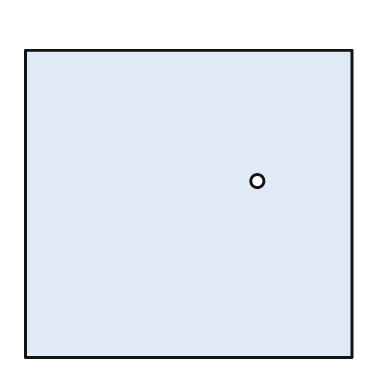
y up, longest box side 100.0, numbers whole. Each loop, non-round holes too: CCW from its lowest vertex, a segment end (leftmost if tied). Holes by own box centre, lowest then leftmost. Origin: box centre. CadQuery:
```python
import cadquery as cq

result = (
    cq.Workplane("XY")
    .moveTo(-50.0, -47.0)
    .lineTo(50.0, -47.0)
    .lineTo(50.0, 47.0)
    .lineTo(-50.0, 47.0)
    .close()
    .moveTo(21.0, 7.0)
    .circle(2.0)
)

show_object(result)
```